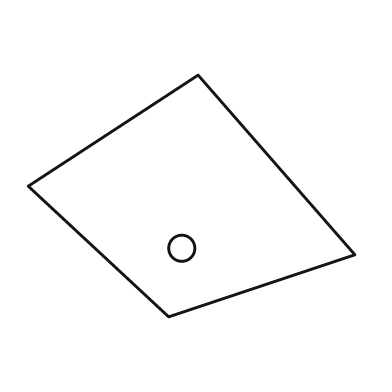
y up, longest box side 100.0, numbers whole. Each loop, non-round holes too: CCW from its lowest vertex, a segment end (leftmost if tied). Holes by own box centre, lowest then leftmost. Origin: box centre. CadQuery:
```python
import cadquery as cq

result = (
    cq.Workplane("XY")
    .moveTo(-7.0, -37.0)
    .lineTo(50.0, -18.0)
    .lineTo(2.0, 37.0)
    .lineTo(-50.0, 3.0)
    .close()
    .moveTo(-3.0, -16.0)
    .circle(4.0)
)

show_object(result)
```